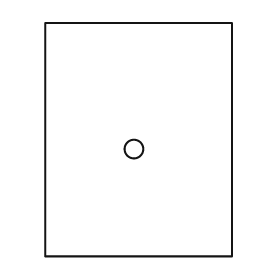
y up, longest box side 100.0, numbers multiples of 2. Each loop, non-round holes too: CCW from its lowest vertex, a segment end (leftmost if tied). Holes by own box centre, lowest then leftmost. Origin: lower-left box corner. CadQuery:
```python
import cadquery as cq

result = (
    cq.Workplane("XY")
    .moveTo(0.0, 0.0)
    .lineTo(80.0, 0.0)
    .lineTo(80.0, 100.0)
    .lineTo(0.0, 100.0)
    .close()
    .moveTo(38.0, 46.0)
    .circle(4.0)
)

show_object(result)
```